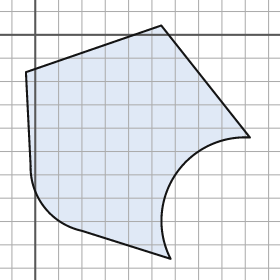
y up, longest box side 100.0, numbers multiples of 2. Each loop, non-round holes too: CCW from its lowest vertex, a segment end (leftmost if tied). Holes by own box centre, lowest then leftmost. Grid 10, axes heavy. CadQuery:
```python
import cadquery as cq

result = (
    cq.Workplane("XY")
    .moveTo(58.0, -96.0)
    .threePointArc((60.0, -60.0), (92.0, -44.0))
    .lineTo(54.0, 4.0)
    .lineTo(-4.0, -16.0)
    .lineTo(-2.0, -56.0)
    .threePointArc((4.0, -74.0), (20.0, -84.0))
    .close()
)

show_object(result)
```